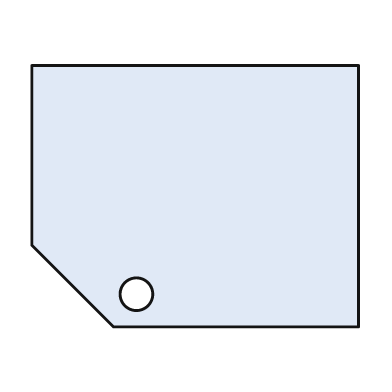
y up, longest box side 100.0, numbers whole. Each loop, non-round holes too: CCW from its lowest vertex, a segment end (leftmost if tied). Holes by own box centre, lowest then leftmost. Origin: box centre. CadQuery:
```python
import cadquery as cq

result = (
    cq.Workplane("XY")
    .moveTo(-25.0, -40.0)
    .lineTo(50.0, -40.0)
    .lineTo(50.0, 40.0)
    .lineTo(-50.0, 40.0)
    .lineTo(-50.0, -15.0)
    .close()
    .moveTo(-18.0, -30.0)
    .circle(5.0)
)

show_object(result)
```